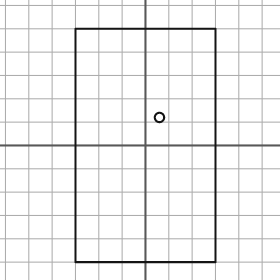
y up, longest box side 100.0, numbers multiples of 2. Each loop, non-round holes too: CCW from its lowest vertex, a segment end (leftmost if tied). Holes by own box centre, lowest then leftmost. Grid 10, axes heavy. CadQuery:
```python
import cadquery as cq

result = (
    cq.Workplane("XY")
    .moveTo(-30.0, -50.0)
    .lineTo(30.0, -50.0)
    .lineTo(30.0, 50.0)
    .lineTo(-30.0, 50.0)
    .close()
    .moveTo(6.0, 12.0)
    .circle(2.0)
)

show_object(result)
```